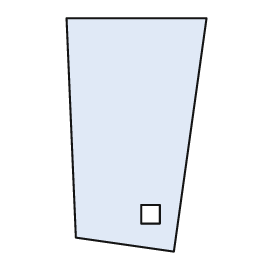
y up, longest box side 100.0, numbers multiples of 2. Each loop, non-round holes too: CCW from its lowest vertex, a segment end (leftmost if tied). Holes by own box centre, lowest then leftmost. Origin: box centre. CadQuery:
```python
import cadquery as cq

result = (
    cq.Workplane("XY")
    .moveTo(16.0, -50.0)
    .lineTo(30.0, 50.0)
    .lineTo(-30.0, 50.0)
    .lineTo(-26.0, -44.0)
    .close()
    .moveTo(2.0, -38.0)
    .lineTo(10.0, -38.0)
    .lineTo(10.0, -30.0)
    .lineTo(2.0, -30.0)
    .close()
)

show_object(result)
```